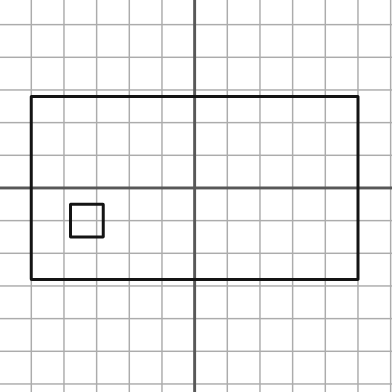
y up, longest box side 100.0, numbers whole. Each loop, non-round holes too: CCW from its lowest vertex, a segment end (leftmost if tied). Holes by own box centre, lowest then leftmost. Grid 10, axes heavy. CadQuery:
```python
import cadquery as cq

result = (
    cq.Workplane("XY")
    .moveTo(-50.0, -28.0)
    .lineTo(50.0, -28.0)
    .lineTo(50.0, 28.0)
    .lineTo(-50.0, 28.0)
    .close()
    .moveTo(-38.0, -15.0)
    .lineTo(-28.0, -15.0)
    .lineTo(-28.0, -5.0)
    .lineTo(-38.0, -5.0)
    .close()
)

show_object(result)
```